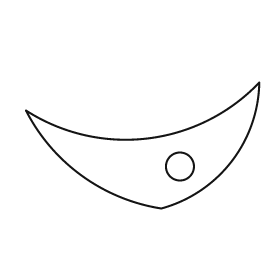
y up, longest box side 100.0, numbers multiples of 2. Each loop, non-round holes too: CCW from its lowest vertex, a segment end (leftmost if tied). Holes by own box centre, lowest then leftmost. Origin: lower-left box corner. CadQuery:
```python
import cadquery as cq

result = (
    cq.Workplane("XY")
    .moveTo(58.0, 0.0)
    .threePointArc((88.0, 20.0), (100.0, 54.0))
    .threePointArc((52.0, 30.0), (0.0, 42.0))
    .threePointArc((24.0, 14.0), (58.0, 0.0))
    .close()
    .moveTo(66.0, 18.0)
    .circle(6.0)
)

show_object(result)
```